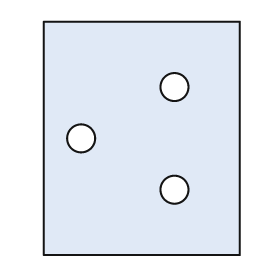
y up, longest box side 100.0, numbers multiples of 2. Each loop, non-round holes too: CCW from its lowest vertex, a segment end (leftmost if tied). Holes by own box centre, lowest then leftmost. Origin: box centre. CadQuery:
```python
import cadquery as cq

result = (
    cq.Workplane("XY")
    .moveTo(-42.0, -50.0)
    .lineTo(42.0, -50.0)
    .lineTo(42.0, 50.0)
    .lineTo(-42.0, 50.0)
    .close()
    .moveTo(14.0, -22.0)
    .circle(6.0)
    .moveTo(-26.0, 0.0)
    .circle(6.0)
    .moveTo(14.0, 22.0)
    .circle(6.0)
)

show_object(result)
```